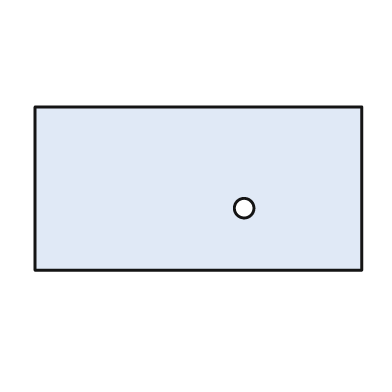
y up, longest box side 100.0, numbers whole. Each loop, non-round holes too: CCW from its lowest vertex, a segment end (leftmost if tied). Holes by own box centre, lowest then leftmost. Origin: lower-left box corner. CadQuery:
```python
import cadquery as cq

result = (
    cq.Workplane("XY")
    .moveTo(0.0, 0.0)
    .lineTo(100.0, 0.0)
    .lineTo(100.0, 50.0)
    .lineTo(0.0, 50.0)
    .close()
    .moveTo(64.0, 19.0)
    .circle(3.0)
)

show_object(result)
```